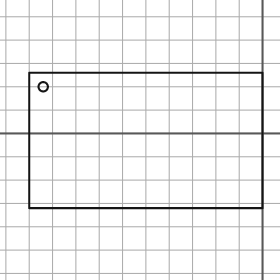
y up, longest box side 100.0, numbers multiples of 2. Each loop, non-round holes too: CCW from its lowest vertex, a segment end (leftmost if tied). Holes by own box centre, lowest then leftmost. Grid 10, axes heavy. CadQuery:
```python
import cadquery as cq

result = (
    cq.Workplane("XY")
    .moveTo(-100.0, -32.0)
    .lineTo(0.0, -32.0)
    .lineTo(0.0, 26.0)
    .lineTo(-100.0, 26.0)
    .close()
    .moveTo(-94.0, 20.0)
    .circle(2.0)
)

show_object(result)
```